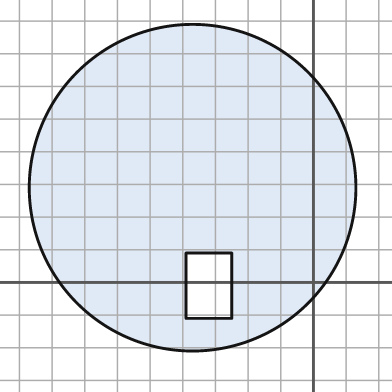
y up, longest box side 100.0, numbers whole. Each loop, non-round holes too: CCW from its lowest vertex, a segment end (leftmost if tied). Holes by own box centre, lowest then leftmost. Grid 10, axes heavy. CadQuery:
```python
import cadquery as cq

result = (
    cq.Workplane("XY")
    .moveTo(-37.0, 29.0)
    .circle(50.0)
    .moveTo(-39.0, -11.0)
    .lineTo(-25.0, -11.0)
    .lineTo(-25.0, 9.0)
    .lineTo(-39.0, 9.0)
    .close()
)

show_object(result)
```